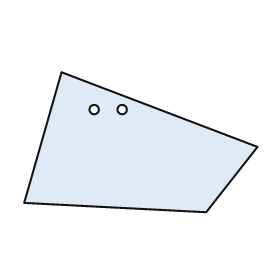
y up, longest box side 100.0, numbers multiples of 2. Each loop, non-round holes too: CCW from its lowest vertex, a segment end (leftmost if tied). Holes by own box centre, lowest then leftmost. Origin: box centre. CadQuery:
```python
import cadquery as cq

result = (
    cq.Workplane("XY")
    .moveTo(28.0, -30.0)
    .lineTo(50.0, -2.0)
    .lineTo(-34.0, 30.0)
    .lineTo(-50.0, -26.0)
    .close()
    .moveTo(-20.0, 14.0)
    .circle(2.0)
    .moveTo(-8.0, 14.0)
    .circle(2.0)
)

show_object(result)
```